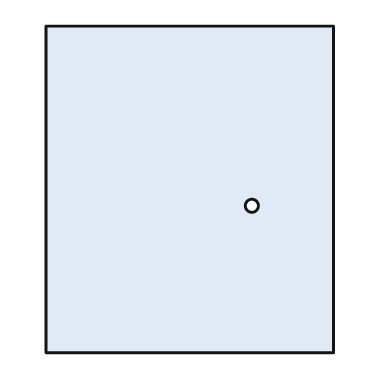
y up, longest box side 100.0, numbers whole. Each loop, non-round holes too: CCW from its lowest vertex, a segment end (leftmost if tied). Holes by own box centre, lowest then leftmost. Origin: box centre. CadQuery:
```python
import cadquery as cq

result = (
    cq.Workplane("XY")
    .moveTo(-44.0, -50.0)
    .lineTo(44.0, -50.0)
    .lineTo(44.0, 50.0)
    .lineTo(-44.0, 50.0)
    .close()
    .moveTo(19.0, -5.0)
    .circle(2.0)
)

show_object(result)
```